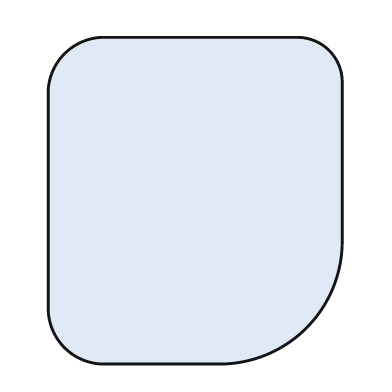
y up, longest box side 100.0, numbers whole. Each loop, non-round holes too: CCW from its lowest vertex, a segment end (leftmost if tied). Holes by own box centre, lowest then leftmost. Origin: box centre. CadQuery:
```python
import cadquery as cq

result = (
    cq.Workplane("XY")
    .moveTo(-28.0, -50.0)
    .lineTo(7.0, -50.0)
    .threePointArc((34.0, -39.0), (45.0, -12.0))
    .lineTo(45.0, 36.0)
    .threePointArc((41.0, 46.0), (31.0, 50.0))
    .lineTo(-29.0, 50.0)
    .threePointArc((-40.0, 45.0), (-45.0, 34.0))
    .lineTo(-45.0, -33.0)
    .threePointArc((-40.0, -45.0), (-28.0, -50.0))
    .close()
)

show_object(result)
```